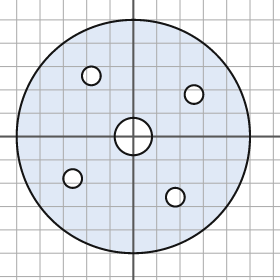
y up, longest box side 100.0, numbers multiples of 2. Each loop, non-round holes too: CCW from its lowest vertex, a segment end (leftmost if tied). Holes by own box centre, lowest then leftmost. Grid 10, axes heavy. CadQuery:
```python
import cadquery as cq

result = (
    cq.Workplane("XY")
    .moveTo(0.0, 0.0)
    .circle(50.0)
    .moveTo(18.0, -26.0)
    .circle(4.0)
    .moveTo(-26.0, -18.0)
    .circle(4.0)
    .moveTo(0.0, 0.0)
    .circle(8.0)
    .moveTo(26.0, 18.0)
    .circle(4.0)
    .moveTo(-18.0, 26.0)
    .circle(4.0)
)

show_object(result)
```